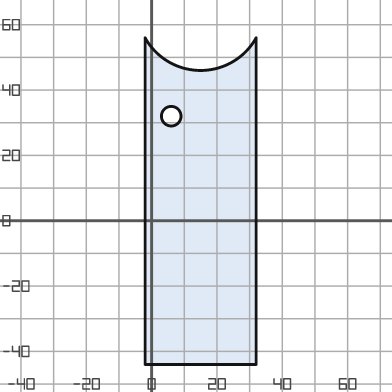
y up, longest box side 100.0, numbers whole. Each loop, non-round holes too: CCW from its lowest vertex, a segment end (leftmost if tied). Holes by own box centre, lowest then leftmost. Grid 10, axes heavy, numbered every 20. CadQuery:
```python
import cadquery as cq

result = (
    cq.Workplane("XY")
    .moveTo(-2.0, -44.0)
    .lineTo(32.0, -44.0)
    .lineTo(32.0, 56.0)
    .threePointArc((15.0, 46.0), (-2.0, 56.0))
    .close()
    .moveTo(6.0, 32.0)
    .circle(3.0)
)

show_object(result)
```